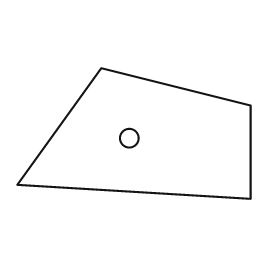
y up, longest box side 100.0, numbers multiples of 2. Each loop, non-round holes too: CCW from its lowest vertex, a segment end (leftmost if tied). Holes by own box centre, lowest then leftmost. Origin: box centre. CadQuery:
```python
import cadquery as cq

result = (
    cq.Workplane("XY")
    .moveTo(50.0, -28.0)
    .lineTo(50.0, 12.0)
    .lineTo(-14.0, 28.0)
    .lineTo(-50.0, -22.0)
    .close()
    .moveTo(-2.0, -2.0)
    .circle(4.0)
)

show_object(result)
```